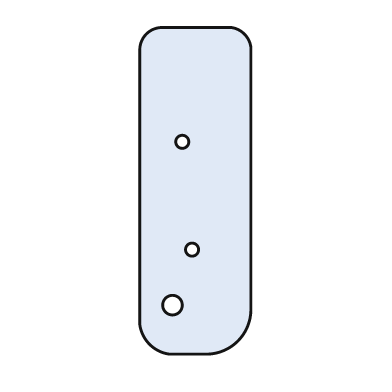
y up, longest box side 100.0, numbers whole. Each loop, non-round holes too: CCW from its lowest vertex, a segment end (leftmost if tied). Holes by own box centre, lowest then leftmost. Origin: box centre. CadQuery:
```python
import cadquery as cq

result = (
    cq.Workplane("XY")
    .moveTo(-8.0, -50.0)
    .lineTo(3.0, -50.0)
    .threePointArc((13.0, -46.0), (17.0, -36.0))
    .lineTo(17.0, 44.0)
    .threePointArc((15.0, 48.0), (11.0, 50.0))
    .lineTo(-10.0, 50.0)
    .threePointArc((-15.0, 48.0), (-17.0, 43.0))
    .lineTo(-17.0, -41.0)
    .threePointArc((-14.0, -47.0), (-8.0, -50.0))
    .close()
    .moveTo(-7.0, -35.0)
    .circle(3.0)
    .moveTo(-1.0, -18.0)
    .circle(2.0)
    .moveTo(-4.0, 15.0)
    .circle(2.0)
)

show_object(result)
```